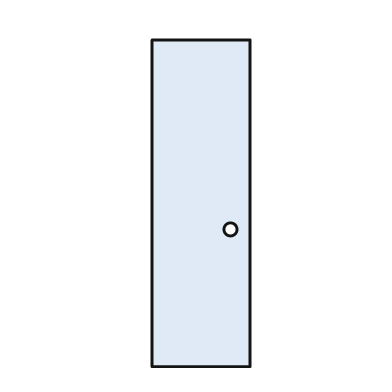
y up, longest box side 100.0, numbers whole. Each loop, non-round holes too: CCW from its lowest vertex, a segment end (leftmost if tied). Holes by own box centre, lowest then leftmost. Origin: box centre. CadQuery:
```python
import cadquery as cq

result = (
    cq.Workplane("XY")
    .moveTo(-15.0, -50.0)
    .lineTo(15.0, -50.0)
    .lineTo(15.0, 50.0)
    .lineTo(-15.0, 50.0)
    .close()
    .moveTo(9.0, -8.0)
    .circle(2.0)
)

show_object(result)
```